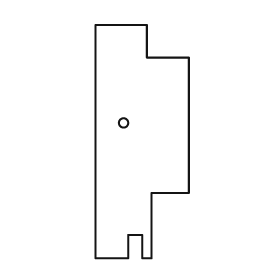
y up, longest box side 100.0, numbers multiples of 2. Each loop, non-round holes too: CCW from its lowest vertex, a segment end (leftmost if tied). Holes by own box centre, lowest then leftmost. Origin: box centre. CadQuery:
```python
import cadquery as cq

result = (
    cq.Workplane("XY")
    .moveTo(-20.0, -50.0)
    .lineTo(-6.0, -50.0)
    .lineTo(-6.0, -40.0)
    .lineTo(0.0, -40.0)
    .lineTo(0.0, -50.0)
    .lineTo(4.0, -50.0)
    .lineTo(4.0, -22.0)
    .lineTo(20.0, -22.0)
    .lineTo(20.0, 36.0)
    .lineTo(2.0, 36.0)
    .lineTo(2.0, 50.0)
    .lineTo(-20.0, 50.0)
    .close()
    .moveTo(-8.0, 8.0)
    .circle(2.0)
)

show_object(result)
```